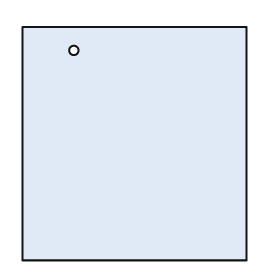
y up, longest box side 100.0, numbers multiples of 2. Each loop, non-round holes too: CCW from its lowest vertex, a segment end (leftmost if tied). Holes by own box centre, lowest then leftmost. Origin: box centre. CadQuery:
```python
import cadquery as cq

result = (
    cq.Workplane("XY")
    .moveTo(-48.0, -50.0)
    .lineTo(48.0, -50.0)
    .lineTo(48.0, 50.0)
    .lineTo(-48.0, 50.0)
    .close()
    .moveTo(-26.0, 40.0)
    .circle(2.0)
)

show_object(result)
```